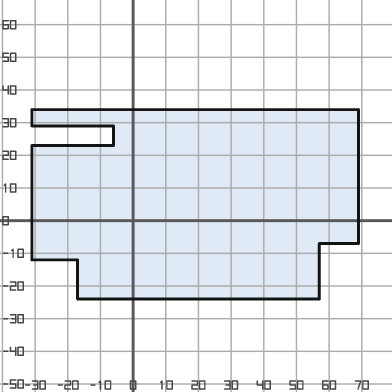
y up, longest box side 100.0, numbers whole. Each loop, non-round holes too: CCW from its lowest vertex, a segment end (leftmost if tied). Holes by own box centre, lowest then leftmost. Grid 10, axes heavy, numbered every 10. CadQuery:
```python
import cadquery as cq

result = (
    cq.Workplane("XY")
    .moveTo(-17.0, -24.0)
    .lineTo(57.0, -24.0)
    .lineTo(57.0, -7.0)
    .lineTo(69.0, -7.0)
    .lineTo(69.0, 34.0)
    .lineTo(-31.0, 34.0)
    .lineTo(-31.0, 29.0)
    .lineTo(-6.0, 29.0)
    .lineTo(-6.0, 23.0)
    .lineTo(-31.0, 23.0)
    .lineTo(-31.0, -12.0)
    .lineTo(-17.0, -12.0)
    .close()
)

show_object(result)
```